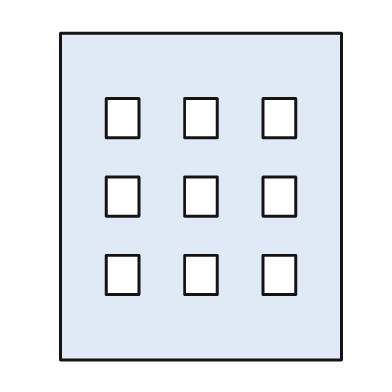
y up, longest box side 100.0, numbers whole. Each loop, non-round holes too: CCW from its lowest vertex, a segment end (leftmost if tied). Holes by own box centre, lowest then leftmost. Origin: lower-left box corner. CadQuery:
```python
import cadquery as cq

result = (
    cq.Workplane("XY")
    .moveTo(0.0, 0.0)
    .lineTo(86.0, 0.0)
    .lineTo(86.0, 100.0)
    .lineTo(0.0, 100.0)
    .close()
    .moveTo(14.0, 20.0)
    .lineTo(24.0, 20.0)
    .lineTo(24.0, 32.0)
    .lineTo(14.0, 32.0)
    .close()
    .moveTo(38.0, 20.0)
    .lineTo(48.0, 20.0)
    .lineTo(48.0, 32.0)
    .lineTo(38.0, 32.0)
    .close()
    .moveTo(62.0, 20.0)
    .lineTo(72.0, 20.0)
    .lineTo(72.0, 32.0)
    .lineTo(62.0, 32.0)
    .close()
    .moveTo(14.0, 44.0)
    .lineTo(24.0, 44.0)
    .lineTo(24.0, 56.0)
    .lineTo(14.0, 56.0)
    .close()
    .moveTo(38.0, 44.0)
    .lineTo(48.0, 44.0)
    .lineTo(48.0, 56.0)
    .lineTo(38.0, 56.0)
    .close()
    .moveTo(62.0, 44.0)
    .lineTo(72.0, 44.0)
    .lineTo(72.0, 56.0)
    .lineTo(62.0, 56.0)
    .close()
    .moveTo(14.0, 68.0)
    .lineTo(24.0, 68.0)
    .lineTo(24.0, 80.0)
    .lineTo(14.0, 80.0)
    .close()
    .moveTo(38.0, 68.0)
    .lineTo(48.0, 68.0)
    .lineTo(48.0, 80.0)
    .lineTo(38.0, 80.0)
    .close()
    .moveTo(62.0, 68.0)
    .lineTo(72.0, 68.0)
    .lineTo(72.0, 80.0)
    .lineTo(62.0, 80.0)
    .close()
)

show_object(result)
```